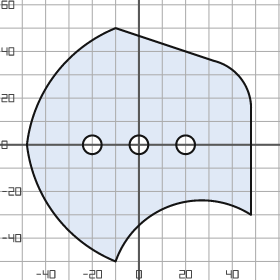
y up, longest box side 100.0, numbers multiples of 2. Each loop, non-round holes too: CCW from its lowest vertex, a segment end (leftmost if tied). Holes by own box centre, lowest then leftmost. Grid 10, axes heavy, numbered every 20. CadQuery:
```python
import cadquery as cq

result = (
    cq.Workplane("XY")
    .moveTo(-10.0, -50.0)
    .threePointArc((14.0, -26.0), (48.0, -30.0))
    .lineTo(48.0, 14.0)
    .threePointArc((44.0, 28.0), (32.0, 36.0))
    .lineTo(-10.0, 50.0)
    .threePointArc((-36.0, 30.0), (-48.0, 0.0))
    .threePointArc((-36.0, -30.0), (-10.0, -50.0))
    .close()
    .moveTo(-20.0, 0.0)
    .circle(4.0)
    .moveTo(0.0, 0.0)
    .circle(4.0)
    .moveTo(20.0, 0.0)
    .circle(4.0)
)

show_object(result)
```